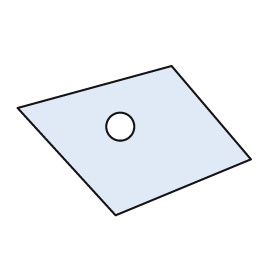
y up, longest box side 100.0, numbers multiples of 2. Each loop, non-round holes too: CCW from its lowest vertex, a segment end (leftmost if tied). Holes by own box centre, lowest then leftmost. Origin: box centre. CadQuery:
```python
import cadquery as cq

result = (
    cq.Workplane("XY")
    .moveTo(-8.0, -32.0)
    .lineTo(50.0, -8.0)
    .lineTo(16.0, 32.0)
    .lineTo(-50.0, 14.0)
    .close()
    .moveTo(-6.0, 6.0)
    .circle(6.0)
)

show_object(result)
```